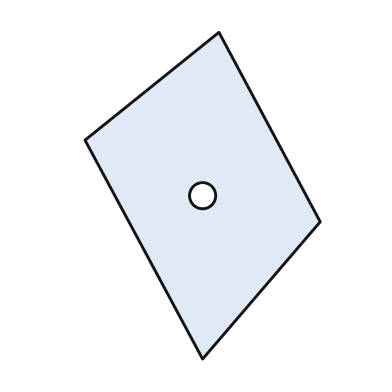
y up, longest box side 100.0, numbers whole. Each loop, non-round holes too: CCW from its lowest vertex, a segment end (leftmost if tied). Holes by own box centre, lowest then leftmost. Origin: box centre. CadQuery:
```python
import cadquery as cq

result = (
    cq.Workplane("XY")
    .moveTo(0.0, -50.0)
    .lineTo(36.0, -8.0)
    .lineTo(5.0, 50.0)
    .lineTo(-36.0, 17.0)
    .close()
    .moveTo(0.0, 0.0)
    .circle(4.0)
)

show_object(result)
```